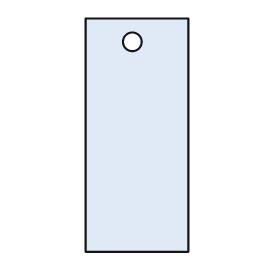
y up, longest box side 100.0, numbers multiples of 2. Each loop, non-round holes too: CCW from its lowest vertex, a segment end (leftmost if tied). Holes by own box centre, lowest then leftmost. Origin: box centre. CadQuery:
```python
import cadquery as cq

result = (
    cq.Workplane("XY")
    .moveTo(-22.0, -50.0)
    .lineTo(22.0, -50.0)
    .lineTo(22.0, 50.0)
    .lineTo(-22.0, 50.0)
    .close()
    .moveTo(-2.0, 40.0)
    .circle(4.0)
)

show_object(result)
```